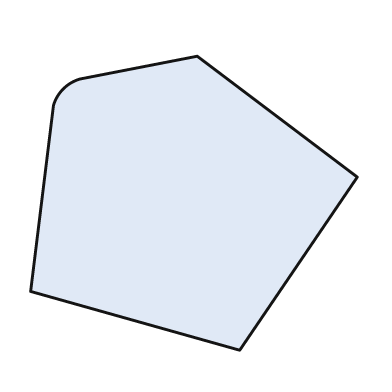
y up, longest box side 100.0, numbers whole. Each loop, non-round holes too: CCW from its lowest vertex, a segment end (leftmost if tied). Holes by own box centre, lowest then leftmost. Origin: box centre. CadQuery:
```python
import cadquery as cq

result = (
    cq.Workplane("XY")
    .moveTo(14.0, -45.0)
    .lineTo(50.0, 8.0)
    .lineTo(1.0, 45.0)
    .lineTo(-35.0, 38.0)
    .threePointArc((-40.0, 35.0), (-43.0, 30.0))
    .lineTo(-50.0, -27.0)
    .close()
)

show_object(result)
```